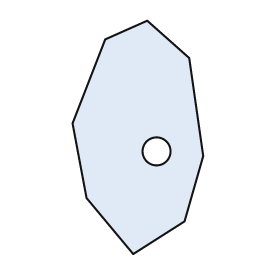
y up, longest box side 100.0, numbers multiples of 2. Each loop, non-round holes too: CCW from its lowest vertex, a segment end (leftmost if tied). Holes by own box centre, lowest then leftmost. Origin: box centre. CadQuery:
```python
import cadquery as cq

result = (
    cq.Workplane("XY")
    .moveTo(-2.0, -50.0)
    .lineTo(20.0, -36.0)
    .lineTo(28.0, -8.0)
    .lineTo(22.0, 34.0)
    .lineTo(4.0, 50.0)
    .lineTo(-14.0, 42.0)
    .lineTo(-28.0, 6.0)
    .lineTo(-22.0, -26.0)
    .close()
    .moveTo(8.0, -6.0)
    .circle(6.0)
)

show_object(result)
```